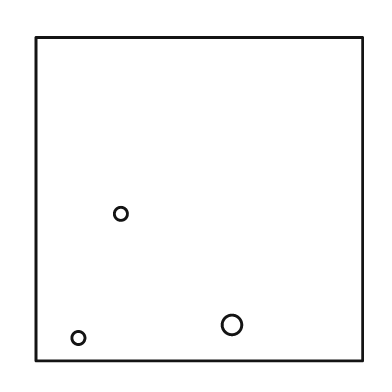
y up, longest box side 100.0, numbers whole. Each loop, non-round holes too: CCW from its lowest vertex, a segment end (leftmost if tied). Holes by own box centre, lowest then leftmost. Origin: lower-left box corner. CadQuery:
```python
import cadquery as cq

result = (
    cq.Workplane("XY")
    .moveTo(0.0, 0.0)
    .lineTo(100.0, 0.0)
    .lineTo(100.0, 99.0)
    .lineTo(0.0, 99.0)
    .close()
    .moveTo(13.0, 7.0)
    .circle(2.0)
    .moveTo(60.0, 11.0)
    .circle(3.0)
    .moveTo(26.0, 45.0)
    .circle(2.0)
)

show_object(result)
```